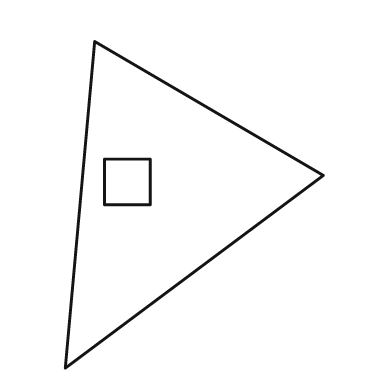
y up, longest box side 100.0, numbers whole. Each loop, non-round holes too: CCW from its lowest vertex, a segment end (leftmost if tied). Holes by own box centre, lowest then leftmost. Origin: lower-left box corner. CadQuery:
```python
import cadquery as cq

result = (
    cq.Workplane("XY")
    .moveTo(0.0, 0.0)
    .lineTo(79.0, 59.0)
    .lineTo(9.0, 100.0)
    .close()
    .moveTo(12.0, 50.0)
    .lineTo(26.0, 50.0)
    .lineTo(26.0, 64.0)
    .lineTo(12.0, 64.0)
    .close()
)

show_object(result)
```